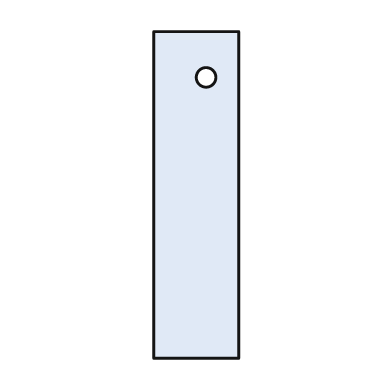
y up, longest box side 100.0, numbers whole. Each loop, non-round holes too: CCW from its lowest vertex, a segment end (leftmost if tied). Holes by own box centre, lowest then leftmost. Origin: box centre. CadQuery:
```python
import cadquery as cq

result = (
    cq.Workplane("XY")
    .moveTo(-13.0, -50.0)
    .lineTo(13.0, -50.0)
    .lineTo(13.0, 50.0)
    .lineTo(-13.0, 50.0)
    .close()
    .moveTo(3.0, 36.0)
    .circle(3.0)
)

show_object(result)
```